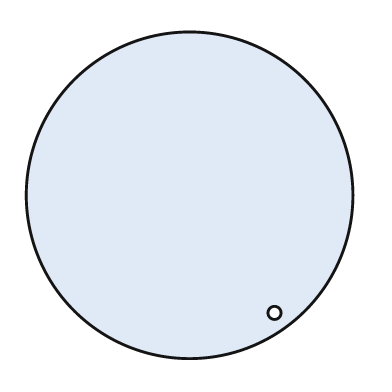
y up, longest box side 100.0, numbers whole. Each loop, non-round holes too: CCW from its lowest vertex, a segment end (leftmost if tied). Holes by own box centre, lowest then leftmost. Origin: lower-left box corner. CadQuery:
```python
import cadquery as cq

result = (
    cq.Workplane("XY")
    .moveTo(50.0, 50.0)
    .circle(50.0)
    .moveTo(76.0, 14.0)
    .circle(2.0)
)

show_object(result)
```